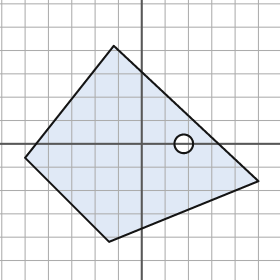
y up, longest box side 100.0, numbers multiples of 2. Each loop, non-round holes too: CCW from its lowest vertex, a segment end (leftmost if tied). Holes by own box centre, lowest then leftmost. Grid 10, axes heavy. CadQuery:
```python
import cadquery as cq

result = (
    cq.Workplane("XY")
    .moveTo(-14.0, -42.0)
    .lineTo(50.0, -16.0)
    .lineTo(-12.0, 42.0)
    .lineTo(-50.0, -6.0)
    .close()
    .moveTo(18.0, 0.0)
    .circle(4.0)
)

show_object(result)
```